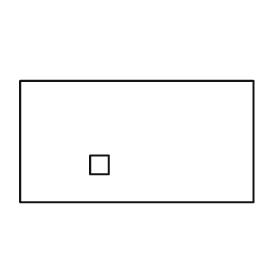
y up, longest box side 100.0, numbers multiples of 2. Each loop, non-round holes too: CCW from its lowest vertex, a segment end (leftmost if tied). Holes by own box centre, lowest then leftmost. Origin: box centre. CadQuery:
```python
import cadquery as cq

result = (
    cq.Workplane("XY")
    .moveTo(-50.0, -26.0)
    .lineTo(50.0, -26.0)
    .lineTo(50.0, 26.0)
    .lineTo(-50.0, 26.0)
    .close()
    .moveTo(-20.0, -14.0)
    .lineTo(-12.0, -14.0)
    .lineTo(-12.0, -6.0)
    .lineTo(-20.0, -6.0)
    .close()
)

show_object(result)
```